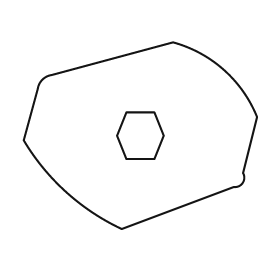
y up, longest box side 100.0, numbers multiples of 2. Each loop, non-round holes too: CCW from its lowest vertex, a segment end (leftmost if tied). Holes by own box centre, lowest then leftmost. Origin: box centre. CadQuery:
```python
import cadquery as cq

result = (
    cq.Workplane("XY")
    .moveTo(-8.0, -40.0)
    .lineTo(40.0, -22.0)
    .threePointArc((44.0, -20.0), (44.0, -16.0))
    .lineTo(50.0, 8.0)
    .threePointArc((36.0, 28.0), (14.0, 40.0))
    .lineTo(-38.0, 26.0)
    .threePointArc((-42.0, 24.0), (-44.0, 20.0))
    .lineTo(-50.0, -2.0)
    .threePointArc((-32.0, -24.0), (-8.0, -40.0))
    .close()
    .moveTo(-6.0, -10.0)
    .lineTo(6.0, -10.0)
    .lineTo(10.0, 0.0)
    .lineTo(6.0, 10.0)
    .lineTo(-6.0, 10.0)
    .lineTo(-10.0, 0.0)
    .close()
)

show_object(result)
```